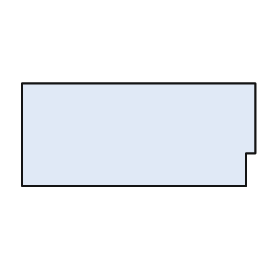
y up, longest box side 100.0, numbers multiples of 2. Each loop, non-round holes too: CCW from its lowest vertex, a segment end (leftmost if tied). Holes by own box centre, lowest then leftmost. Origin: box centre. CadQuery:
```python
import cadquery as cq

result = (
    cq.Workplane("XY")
    .moveTo(-50.0, -22.0)
    .lineTo(46.0, -22.0)
    .lineTo(46.0, -8.0)
    .lineTo(50.0, -8.0)
    .lineTo(50.0, 22.0)
    .lineTo(-50.0, 22.0)
    .close()
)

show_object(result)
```